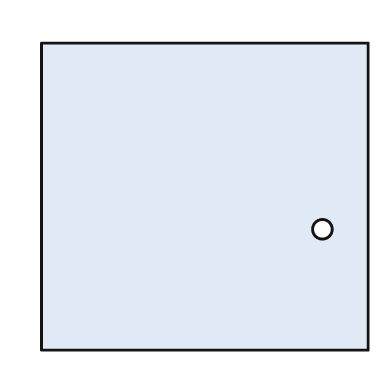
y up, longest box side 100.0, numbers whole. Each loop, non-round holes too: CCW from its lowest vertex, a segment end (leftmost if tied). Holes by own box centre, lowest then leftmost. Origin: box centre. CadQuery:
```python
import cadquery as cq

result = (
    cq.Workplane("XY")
    .moveTo(-50.0, -47.0)
    .lineTo(50.0, -47.0)
    .lineTo(50.0, 47.0)
    .lineTo(-50.0, 47.0)
    .close()
    .moveTo(36.0, -10.0)
    .circle(3.0)
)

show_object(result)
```